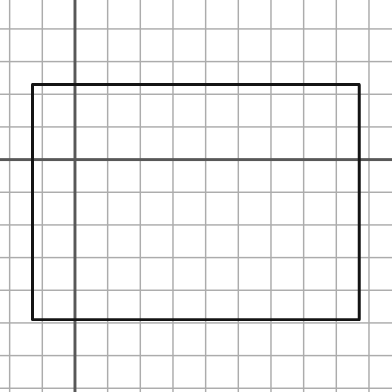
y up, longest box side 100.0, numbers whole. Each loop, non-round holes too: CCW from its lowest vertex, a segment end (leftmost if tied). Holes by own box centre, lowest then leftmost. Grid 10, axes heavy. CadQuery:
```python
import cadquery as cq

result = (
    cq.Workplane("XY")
    .moveTo(-13.0, -49.0)
    .lineTo(87.0, -49.0)
    .lineTo(87.0, 23.0)
    .lineTo(-13.0, 23.0)
    .close()
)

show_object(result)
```